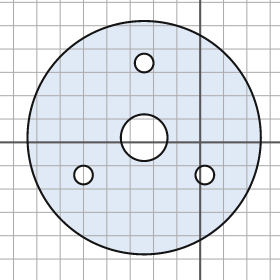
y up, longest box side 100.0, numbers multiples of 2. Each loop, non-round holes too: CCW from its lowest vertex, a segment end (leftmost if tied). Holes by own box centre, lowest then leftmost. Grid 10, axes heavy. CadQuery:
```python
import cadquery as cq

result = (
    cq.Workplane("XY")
    .moveTo(-24.0, 2.0)
    .circle(50.0)
    .moveTo(-50.0, -14.0)
    .circle(4.0)
    .moveTo(2.0, -14.0)
    .circle(4.0)
    .moveTo(-24.0, 2.0)
    .circle(10.0)
    .moveTo(-24.0, 34.0)
    .circle(4.0)
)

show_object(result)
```